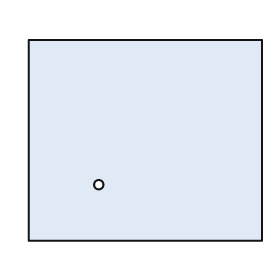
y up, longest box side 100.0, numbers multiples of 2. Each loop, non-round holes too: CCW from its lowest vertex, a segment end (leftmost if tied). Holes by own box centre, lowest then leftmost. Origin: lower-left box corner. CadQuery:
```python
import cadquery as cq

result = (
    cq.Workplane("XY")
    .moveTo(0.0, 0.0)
    .lineTo(100.0, 0.0)
    .lineTo(100.0, 86.0)
    .lineTo(0.0, 86.0)
    .close()
    .moveTo(30.0, 24.0)
    .circle(2.0)
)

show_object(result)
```